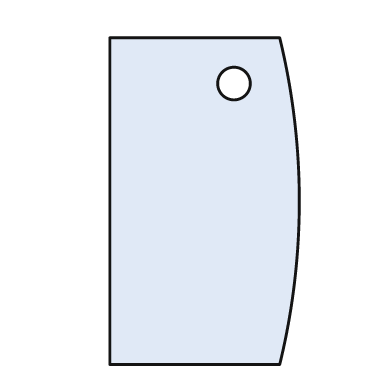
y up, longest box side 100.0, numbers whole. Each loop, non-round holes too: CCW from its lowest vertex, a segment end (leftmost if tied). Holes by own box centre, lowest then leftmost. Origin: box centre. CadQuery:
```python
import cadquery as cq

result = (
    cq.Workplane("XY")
    .moveTo(-29.0, -50.0)
    .lineTo(23.0, -50.0)
    .threePointArc((29.0, 0.0), (23.0, 50.0))
    .lineTo(-29.0, 50.0)
    .close()
    .moveTo(9.0, 36.0)
    .circle(5.0)
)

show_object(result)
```